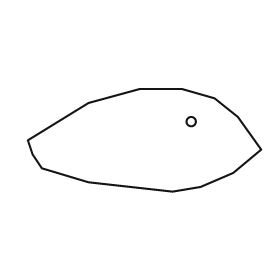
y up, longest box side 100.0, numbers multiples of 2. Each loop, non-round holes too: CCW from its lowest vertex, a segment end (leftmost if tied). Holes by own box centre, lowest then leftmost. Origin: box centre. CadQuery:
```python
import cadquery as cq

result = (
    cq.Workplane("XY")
    .moveTo(12.0, -22.0)
    .lineTo(24.0, -20.0)
    .lineTo(38.0, -14.0)
    .lineTo(50.0, -4.0)
    .lineTo(40.0, 10.0)
    .lineTo(30.0, 18.0)
    .lineTo(16.0, 22.0)
    .lineTo(-2.0, 22.0)
    .lineTo(-24.0, 16.0)
    .lineTo(-50.0, 0.0)
    .lineTo(-48.0, -6.0)
    .lineTo(-44.0, -12.0)
    .lineTo(-24.0, -18.0)
    .close()
    .moveTo(20.0, 8.0)
    .circle(2.0)
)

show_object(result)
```